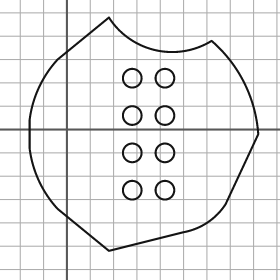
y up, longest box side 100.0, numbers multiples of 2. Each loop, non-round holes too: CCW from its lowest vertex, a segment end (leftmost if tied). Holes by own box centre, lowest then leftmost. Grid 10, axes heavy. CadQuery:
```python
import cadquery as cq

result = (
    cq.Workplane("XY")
    .moveTo(18.0, -52.0)
    .lineTo(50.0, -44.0)
    .threePointArc((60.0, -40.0), (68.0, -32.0))
    .lineTo(82.0, -2.0)
    .threePointArc((76.0, 20.0), (62.0, 38.0))
    .threePointArc((38.0, 34.0), (18.0, 48.0))
    .lineTo(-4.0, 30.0)
    .threePointArc((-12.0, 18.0), (-16.0, 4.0))
    .lineTo(-16.0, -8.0)
    .threePointArc((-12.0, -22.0), (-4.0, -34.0))
    .close()
    .moveTo(28.0, -26.0)
    .circle(4.0)
    .moveTo(42.0, -26.0)
    .circle(4.0)
    .moveTo(28.0, -10.0)
    .circle(4.0)
    .moveTo(42.0, -10.0)
    .circle(4.0)
    .moveTo(28.0, 6.0)
    .circle(4.0)
    .moveTo(42.0, 6.0)
    .circle(4.0)
    .moveTo(28.0, 22.0)
    .circle(4.0)
    .moveTo(42.0, 22.0)
    .circle(4.0)
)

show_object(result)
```